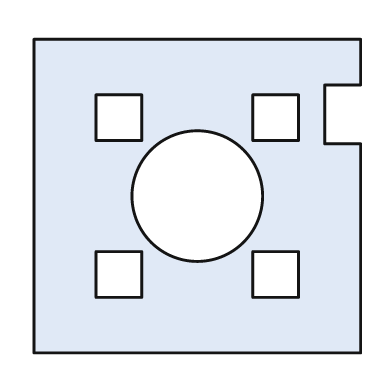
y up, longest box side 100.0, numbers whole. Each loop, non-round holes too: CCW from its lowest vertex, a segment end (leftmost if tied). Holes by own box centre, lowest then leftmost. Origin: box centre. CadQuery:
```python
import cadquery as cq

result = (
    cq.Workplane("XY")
    .moveTo(-50.0, -48.0)
    .lineTo(50.0, -48.0)
    .lineTo(50.0, 16.0)
    .lineTo(39.0, 16.0)
    .lineTo(39.0, 34.0)
    .lineTo(50.0, 34.0)
    .lineTo(50.0, 48.0)
    .lineTo(-50.0, 48.0)
    .close()
    .moveTo(-31.0, -31.0)
    .lineTo(-17.0, -31.0)
    .lineTo(-17.0, -17.0)
    .lineTo(-31.0, -17.0)
    .close()
    .moveTo(17.0, -31.0)
    .lineTo(31.0, -31.0)
    .lineTo(31.0, -17.0)
    .lineTo(17.0, -17.0)
    .close()
    .moveTo(0.0, 0.0)
    .circle(20.0)
    .moveTo(-31.0, 17.0)
    .lineTo(-17.0, 17.0)
    .lineTo(-17.0, 31.0)
    .lineTo(-31.0, 31.0)
    .close()
    .moveTo(17.0, 17.0)
    .lineTo(31.0, 17.0)
    .lineTo(31.0, 31.0)
    .lineTo(17.0, 31.0)
    .close()
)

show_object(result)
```